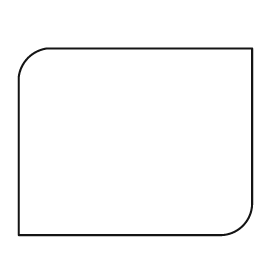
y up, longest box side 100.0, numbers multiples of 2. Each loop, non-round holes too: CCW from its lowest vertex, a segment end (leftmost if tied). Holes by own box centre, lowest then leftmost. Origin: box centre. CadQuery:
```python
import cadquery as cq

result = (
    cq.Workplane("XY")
    .moveTo(-50.0, -40.0)
    .lineTo(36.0, -40.0)
    .threePointArc((46.0, -36.0), (50.0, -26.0))
    .lineTo(50.0, 40.0)
    .lineTo(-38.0, 40.0)
    .threePointArc((-46.0, 36.0), (-50.0, 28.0))
    .close()
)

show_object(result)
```